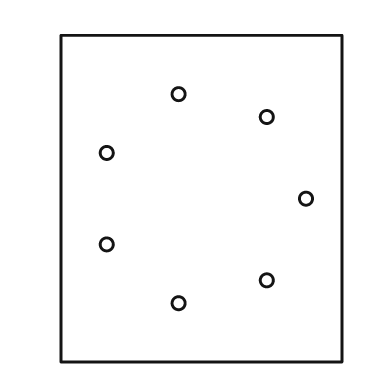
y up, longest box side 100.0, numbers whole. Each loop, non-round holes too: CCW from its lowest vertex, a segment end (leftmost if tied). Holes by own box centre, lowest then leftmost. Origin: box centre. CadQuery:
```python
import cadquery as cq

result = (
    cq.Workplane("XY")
    .moveTo(-43.0, -50.0)
    .lineTo(43.0, -50.0)
    .lineTo(43.0, 50.0)
    .lineTo(-43.0, 50.0)
    .close()
    .moveTo(-7.0, -32.0)
    .circle(2.0)
    .moveTo(20.0, -25.0)
    .circle(2.0)
    .moveTo(-29.0, -14.0)
    .circle(2.0)
    .moveTo(32.0, 0.0)
    .circle(2.0)
    .moveTo(-29.0, 14.0)
    .circle(2.0)
    .moveTo(20.0, 25.0)
    .circle(2.0)
    .moveTo(-7.0, 32.0)
    .circle(2.0)
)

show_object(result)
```